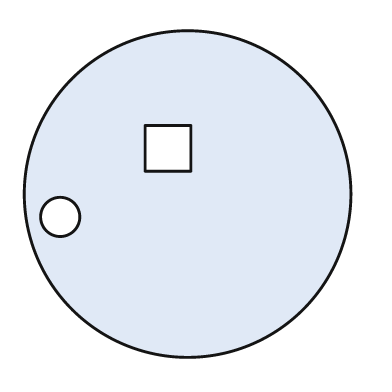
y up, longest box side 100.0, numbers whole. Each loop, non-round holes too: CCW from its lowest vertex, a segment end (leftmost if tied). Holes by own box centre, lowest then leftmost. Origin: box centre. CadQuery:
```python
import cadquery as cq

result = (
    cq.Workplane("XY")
    .moveTo(0.0, 0.0)
    .circle(50.0)
    .moveTo(-39.0, -7.0)
    .circle(6.0)
    .moveTo(-13.0, 7.0)
    .lineTo(1.0, 7.0)
    .lineTo(1.0, 21.0)
    .lineTo(-13.0, 21.0)
    .close()
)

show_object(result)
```